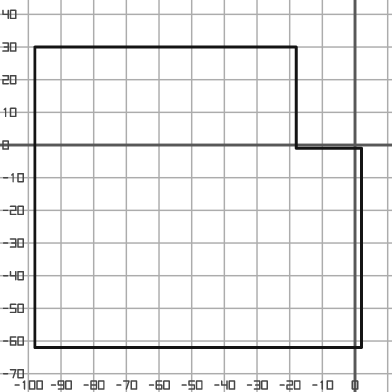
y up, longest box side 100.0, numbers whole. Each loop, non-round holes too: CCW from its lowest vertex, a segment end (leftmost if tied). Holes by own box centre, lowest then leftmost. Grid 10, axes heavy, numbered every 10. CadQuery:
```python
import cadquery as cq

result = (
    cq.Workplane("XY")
    .moveTo(-98.0, -62.0)
    .lineTo(2.0, -62.0)
    .lineTo(2.0, -1.0)
    .lineTo(-18.0, -1.0)
    .lineTo(-18.0, 30.0)
    .lineTo(-98.0, 30.0)
    .close()
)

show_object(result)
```